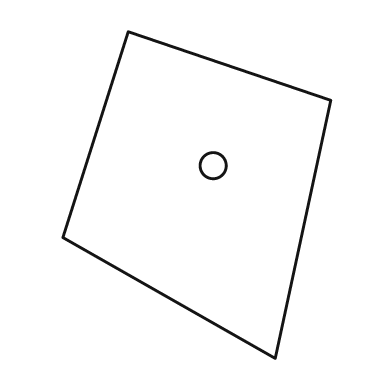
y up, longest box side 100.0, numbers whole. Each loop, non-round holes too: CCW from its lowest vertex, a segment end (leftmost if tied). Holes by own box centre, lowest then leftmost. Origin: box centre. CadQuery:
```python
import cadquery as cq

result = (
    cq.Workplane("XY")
    .moveTo(24.0, -50.0)
    .lineTo(41.0, 29.0)
    .lineTo(-21.0, 50.0)
    .lineTo(-41.0, -13.0)
    .close()
    .moveTo(5.0, 9.0)
    .circle(4.0)
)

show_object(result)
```